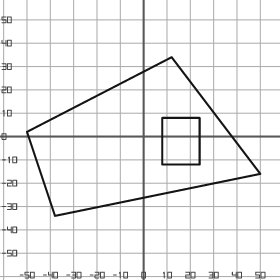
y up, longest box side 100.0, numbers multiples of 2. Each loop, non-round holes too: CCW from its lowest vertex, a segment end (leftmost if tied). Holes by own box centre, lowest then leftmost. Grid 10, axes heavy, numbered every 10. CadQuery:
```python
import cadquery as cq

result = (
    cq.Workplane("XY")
    .moveTo(-38.0, -34.0)
    .lineTo(50.0, -16.0)
    .lineTo(12.0, 34.0)
    .lineTo(-50.0, 2.0)
    .close()
    .moveTo(8.0, -12.0)
    .lineTo(24.0, -12.0)
    .lineTo(24.0, 8.0)
    .lineTo(8.0, 8.0)
    .close()
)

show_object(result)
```